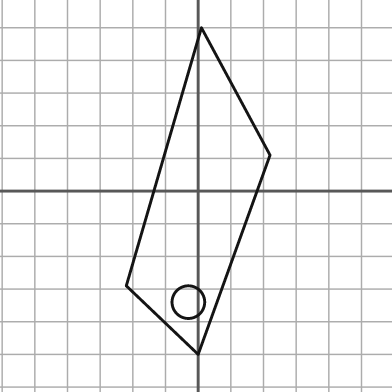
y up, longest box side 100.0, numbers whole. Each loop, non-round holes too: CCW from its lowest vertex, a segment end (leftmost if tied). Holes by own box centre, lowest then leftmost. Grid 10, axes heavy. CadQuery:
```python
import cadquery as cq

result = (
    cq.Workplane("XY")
    .moveTo(0.0, -50.0)
    .lineTo(22.0, 11.0)
    .lineTo(1.0, 50.0)
    .lineTo(-22.0, -29.0)
    .close()
    .moveTo(-3.0, -34.0)
    .circle(5.0)
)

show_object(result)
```